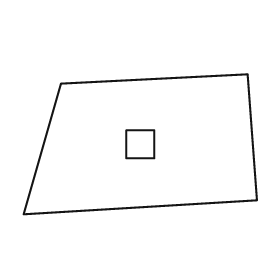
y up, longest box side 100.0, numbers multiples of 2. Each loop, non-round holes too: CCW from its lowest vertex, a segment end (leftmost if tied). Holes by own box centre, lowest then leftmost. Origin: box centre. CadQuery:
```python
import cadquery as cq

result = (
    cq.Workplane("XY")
    .moveTo(-50.0, -30.0)
    .lineTo(50.0, -24.0)
    .lineTo(46.0, 30.0)
    .lineTo(-34.0, 26.0)
    .close()
    .moveTo(-6.0, -6.0)
    .lineTo(6.0, -6.0)
    .lineTo(6.0, 6.0)
    .lineTo(-6.0, 6.0)
    .close()
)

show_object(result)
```